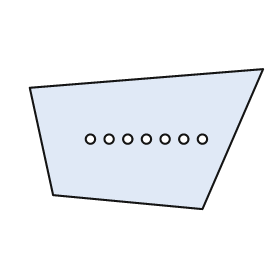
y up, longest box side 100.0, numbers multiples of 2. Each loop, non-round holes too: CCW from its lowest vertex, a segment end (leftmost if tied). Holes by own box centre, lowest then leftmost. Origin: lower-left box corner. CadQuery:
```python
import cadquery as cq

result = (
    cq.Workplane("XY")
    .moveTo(74.0, 0.0)
    .lineTo(100.0, 60.0)
    .lineTo(0.0, 52.0)
    .lineTo(10.0, 6.0)
    .close()
    .moveTo(26.0, 30.0)
    .circle(2.0)
    .moveTo(34.0, 30.0)
    .circle(2.0)
    .moveTo(42.0, 30.0)
    .circle(2.0)
    .moveTo(50.0, 30.0)
    .circle(2.0)
    .moveTo(58.0, 30.0)
    .circle(2.0)
    .moveTo(66.0, 30.0)
    .circle(2.0)
    .moveTo(74.0, 30.0)
    .circle(2.0)
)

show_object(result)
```